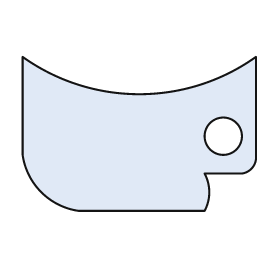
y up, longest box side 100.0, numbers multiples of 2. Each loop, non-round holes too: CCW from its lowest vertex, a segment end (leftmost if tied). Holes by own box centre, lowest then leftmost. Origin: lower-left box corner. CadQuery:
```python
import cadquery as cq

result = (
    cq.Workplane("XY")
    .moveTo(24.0, 0.0)
    .lineTo(78.0, 0.0)
    .threePointArc((80.0, 8.0), (78.0, 16.0))
    .lineTo(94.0, 16.0)
    .threePointArc((98.0, 18.0), (100.0, 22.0))
    .lineTo(100.0, 66.0)
    .threePointArc((50.0, 50.0), (0.0, 66.0))
    .lineTo(0.0, 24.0)
    .threePointArc((8.0, 8.0), (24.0, 0.0))
    .close()
    .moveTo(86.0, 32.0)
    .circle(8.0)
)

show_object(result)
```